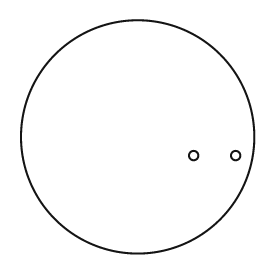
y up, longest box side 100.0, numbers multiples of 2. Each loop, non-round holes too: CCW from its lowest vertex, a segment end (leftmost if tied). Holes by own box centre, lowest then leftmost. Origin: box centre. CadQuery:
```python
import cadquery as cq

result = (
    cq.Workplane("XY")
    .moveTo(0.0, 0.0)
    .circle(50.0)
    .moveTo(24.0, -8.0)
    .circle(2.0)
    .moveTo(42.0, -8.0)
    .circle(2.0)
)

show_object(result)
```